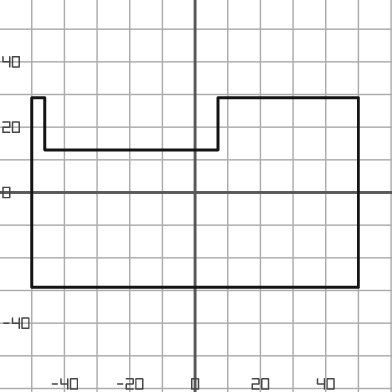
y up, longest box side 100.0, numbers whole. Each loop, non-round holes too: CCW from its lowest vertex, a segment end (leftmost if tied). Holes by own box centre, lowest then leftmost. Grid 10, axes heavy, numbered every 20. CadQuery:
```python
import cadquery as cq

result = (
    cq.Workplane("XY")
    .moveTo(-50.0, -29.0)
    .lineTo(50.0, -29.0)
    .lineTo(50.0, 29.0)
    .lineTo(7.0, 29.0)
    .lineTo(7.0, 13.0)
    .lineTo(-46.0, 13.0)
    .lineTo(-46.0, 29.0)
    .lineTo(-50.0, 29.0)
    .close()
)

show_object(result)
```